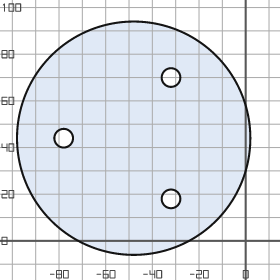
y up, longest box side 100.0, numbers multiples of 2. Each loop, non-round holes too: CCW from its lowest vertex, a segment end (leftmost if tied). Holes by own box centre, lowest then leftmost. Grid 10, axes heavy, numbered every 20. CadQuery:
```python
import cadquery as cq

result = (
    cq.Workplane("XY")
    .moveTo(-48.0, 44.0)
    .circle(50.0)
    .moveTo(-32.0, 18.0)
    .circle(4.0)
    .moveTo(-78.0, 44.0)
    .circle(4.0)
    .moveTo(-32.0, 70.0)
    .circle(4.0)
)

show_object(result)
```